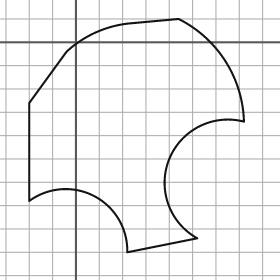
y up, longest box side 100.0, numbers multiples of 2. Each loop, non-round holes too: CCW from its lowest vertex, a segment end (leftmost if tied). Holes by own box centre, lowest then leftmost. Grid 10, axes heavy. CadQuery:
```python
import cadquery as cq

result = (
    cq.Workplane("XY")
    .moveTo(22.0, -90.0)
    .lineTo(52.0, -84.0)
    .threePointArc((40.0, -50.0), (72.0, -34.0))
    .threePointArc((64.0, -8.0), (44.0, 10.0))
    .lineTo(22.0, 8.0)
    .threePointArc((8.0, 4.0), (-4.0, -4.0))
    .lineTo(-20.0, -26.0)
    .lineTo(-20.0, -68.0)
    .threePointArc((8.0, -66.0), (22.0, -90.0))
    .close()
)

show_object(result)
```